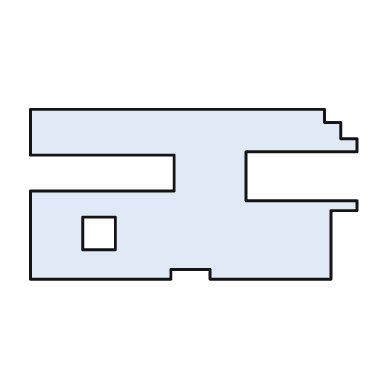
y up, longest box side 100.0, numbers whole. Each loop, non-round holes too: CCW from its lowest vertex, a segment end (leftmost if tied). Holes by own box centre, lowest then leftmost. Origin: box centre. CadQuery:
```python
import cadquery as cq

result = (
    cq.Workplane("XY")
    .moveTo(-50.0, -26.0)
    .lineTo(-7.0, -26.0)
    .lineTo(-7.0, -23.0)
    .lineTo(5.0, -23.0)
    .lineTo(5.0, -26.0)
    .lineTo(42.0, -26.0)
    .lineTo(42.0, -5.0)
    .lineTo(50.0, -5.0)
    .lineTo(50.0, -2.0)
    .lineTo(16.0, -2.0)
    .lineTo(16.0, 13.0)
    .lineTo(50.0, 13.0)
    .lineTo(50.0, 17.0)
    .lineTo(45.0, 17.0)
    .lineTo(45.0, 22.0)
    .lineTo(40.0, 22.0)
    .lineTo(40.0, 26.0)
    .lineTo(-50.0, 26.0)
    .lineTo(-50.0, 12.0)
    .lineTo(-6.0, 12.0)
    .lineTo(-6.0, 1.0)
    .lineTo(-50.0, 1.0)
    .close()
    .moveTo(-34.0, -17.0)
    .lineTo(-24.0, -17.0)
    .lineTo(-24.0, -7.0)
    .lineTo(-34.0, -7.0)
    .close()
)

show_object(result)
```